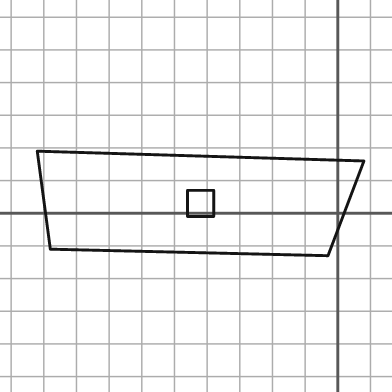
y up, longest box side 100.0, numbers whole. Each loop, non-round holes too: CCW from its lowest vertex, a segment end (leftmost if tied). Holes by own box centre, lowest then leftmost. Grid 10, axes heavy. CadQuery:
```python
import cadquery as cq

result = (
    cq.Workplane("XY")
    .moveTo(-3.0, -13.0)
    .lineTo(8.0, 16.0)
    .lineTo(-92.0, 19.0)
    .lineTo(-88.0, -11.0)
    .close()
    .moveTo(-46.0, -1.0)
    .lineTo(-38.0, -1.0)
    .lineTo(-38.0, 7.0)
    .lineTo(-46.0, 7.0)
    .close()
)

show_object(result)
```